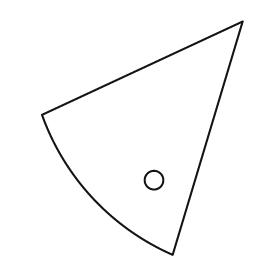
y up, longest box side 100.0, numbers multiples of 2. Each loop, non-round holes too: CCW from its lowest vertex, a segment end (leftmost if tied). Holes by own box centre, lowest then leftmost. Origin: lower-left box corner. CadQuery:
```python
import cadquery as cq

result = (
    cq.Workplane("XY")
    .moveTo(56.0, 0.0)
    .lineTo(86.0, 100.0)
    .lineTo(0.0, 60.0)
    .threePointArc((22.0, 24.0), (56.0, 0.0))
    .close()
    .moveTo(48.0, 32.0)
    .circle(4.0)
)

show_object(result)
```